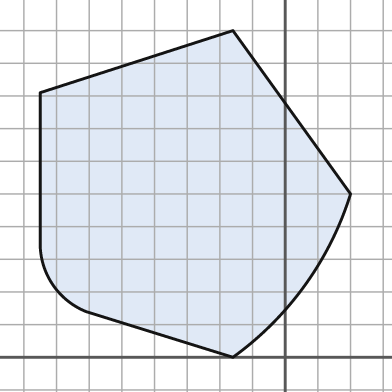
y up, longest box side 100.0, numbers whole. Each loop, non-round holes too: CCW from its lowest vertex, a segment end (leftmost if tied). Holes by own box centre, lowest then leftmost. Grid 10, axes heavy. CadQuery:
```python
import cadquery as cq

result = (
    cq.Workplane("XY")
    .moveTo(-16.0, 0.0)
    .threePointArc((6.0, 22.0), (20.0, 50.0))
    .lineTo(-16.0, 100.0)
    .lineTo(-75.0, 81.0)
    .lineTo(-75.0, 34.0)
    .threePointArc((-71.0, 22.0), (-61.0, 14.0))
    .close()
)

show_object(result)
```